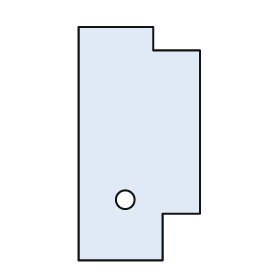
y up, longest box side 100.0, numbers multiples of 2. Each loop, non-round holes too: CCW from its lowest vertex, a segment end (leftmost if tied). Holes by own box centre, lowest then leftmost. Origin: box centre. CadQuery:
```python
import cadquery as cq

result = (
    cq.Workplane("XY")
    .moveTo(-26.0, -50.0)
    .lineTo(10.0, -50.0)
    .lineTo(10.0, -30.0)
    .lineTo(26.0, -30.0)
    .lineTo(26.0, 40.0)
    .lineTo(6.0, 40.0)
    .lineTo(6.0, 50.0)
    .lineTo(-26.0, 50.0)
    .close()
    .moveTo(-6.0, -24.0)
    .circle(4.0)
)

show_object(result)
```